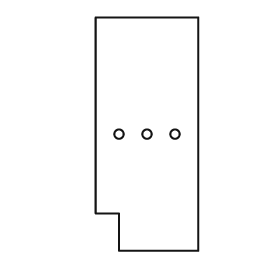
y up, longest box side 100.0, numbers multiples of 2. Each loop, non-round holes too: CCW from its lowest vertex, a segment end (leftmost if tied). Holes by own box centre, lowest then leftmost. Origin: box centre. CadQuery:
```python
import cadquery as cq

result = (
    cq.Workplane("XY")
    .moveTo(-12.0, -50.0)
    .lineTo(22.0, -50.0)
    .lineTo(22.0, 50.0)
    .lineTo(-22.0, 50.0)
    .lineTo(-22.0, -34.0)
    .lineTo(-12.0, -34.0)
    .close()
    .moveTo(-12.0, 0.0)
    .circle(2.0)
    .moveTo(0.0, 0.0)
    .circle(2.0)
    .moveTo(12.0, 0.0)
    .circle(2.0)
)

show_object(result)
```